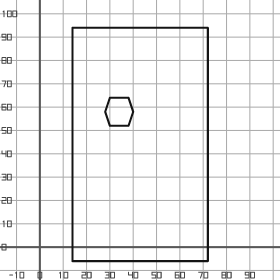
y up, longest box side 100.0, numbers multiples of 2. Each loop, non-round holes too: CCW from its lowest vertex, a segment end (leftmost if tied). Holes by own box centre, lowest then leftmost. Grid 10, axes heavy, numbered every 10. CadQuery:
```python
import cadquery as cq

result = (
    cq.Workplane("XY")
    .moveTo(14.0, -6.0)
    .lineTo(72.0, -6.0)
    .lineTo(72.0, 94.0)
    .lineTo(14.0, 94.0)
    .close()
    .moveTo(30.0, 52.0)
    .lineTo(38.0, 52.0)
    .lineTo(40.0, 58.0)
    .lineTo(38.0, 64.0)
    .lineTo(30.0, 64.0)
    .lineTo(28.0, 58.0)
    .close()
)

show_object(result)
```